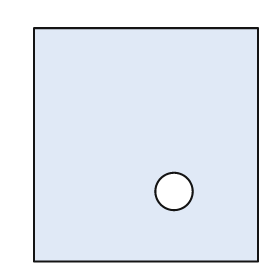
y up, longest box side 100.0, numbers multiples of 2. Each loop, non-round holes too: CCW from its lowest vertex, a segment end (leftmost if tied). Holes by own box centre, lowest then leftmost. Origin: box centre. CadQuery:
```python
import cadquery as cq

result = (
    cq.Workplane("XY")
    .moveTo(-48.0, -50.0)
    .lineTo(48.0, -50.0)
    .lineTo(48.0, 50.0)
    .lineTo(-48.0, 50.0)
    .close()
    .moveTo(12.0, -20.0)
    .circle(8.0)
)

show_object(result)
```